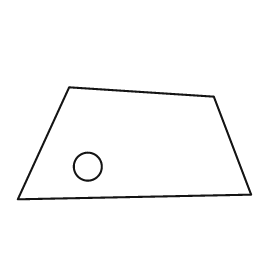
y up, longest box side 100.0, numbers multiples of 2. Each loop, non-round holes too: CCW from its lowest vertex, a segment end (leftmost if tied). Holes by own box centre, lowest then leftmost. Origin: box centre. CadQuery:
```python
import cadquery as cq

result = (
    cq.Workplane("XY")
    .moveTo(-50.0, -24.0)
    .lineTo(50.0, -22.0)
    .lineTo(34.0, 20.0)
    .lineTo(-28.0, 24.0)
    .close()
    .moveTo(-20.0, -10.0)
    .circle(6.0)
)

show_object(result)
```